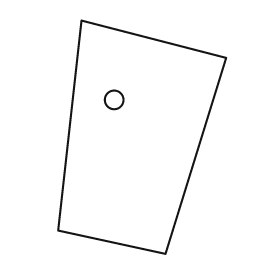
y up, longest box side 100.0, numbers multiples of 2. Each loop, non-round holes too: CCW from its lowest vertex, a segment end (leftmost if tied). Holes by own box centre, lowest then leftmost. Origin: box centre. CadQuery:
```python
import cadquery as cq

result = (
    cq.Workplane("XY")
    .moveTo(10.0, -50.0)
    .lineTo(36.0, 34.0)
    .lineTo(-26.0, 50.0)
    .lineTo(-36.0, -40.0)
    .close()
    .moveTo(-12.0, 16.0)
    .circle(4.0)
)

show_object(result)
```